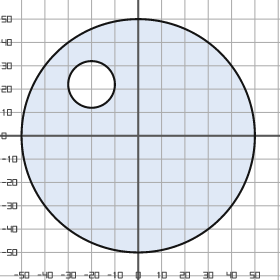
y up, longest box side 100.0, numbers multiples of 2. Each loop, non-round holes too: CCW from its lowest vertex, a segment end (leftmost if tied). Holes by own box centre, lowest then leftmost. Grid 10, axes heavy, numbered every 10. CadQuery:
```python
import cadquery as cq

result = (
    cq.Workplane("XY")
    .moveTo(0.0, 0.0)
    .circle(50.0)
    .moveTo(-20.0, 22.0)
    .circle(10.0)
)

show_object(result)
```